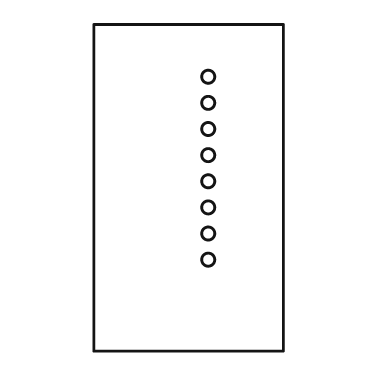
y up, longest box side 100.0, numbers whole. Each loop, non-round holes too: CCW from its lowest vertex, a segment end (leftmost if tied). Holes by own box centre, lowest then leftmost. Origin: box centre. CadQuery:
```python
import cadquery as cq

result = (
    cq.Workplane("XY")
    .moveTo(-29.0, -50.0)
    .lineTo(29.0, -50.0)
    .lineTo(29.0, 50.0)
    .lineTo(-29.0, 50.0)
    .close()
    .moveTo(6.0, -22.0)
    .circle(2.0)
    .moveTo(6.0, -14.0)
    .circle(2.0)
    .moveTo(6.0, -6.0)
    .circle(2.0)
    .moveTo(6.0, 2.0)
    .circle(2.0)
    .moveTo(6.0, 10.0)
    .circle(2.0)
    .moveTo(6.0, 18.0)
    .circle(2.0)
    .moveTo(6.0, 26.0)
    .circle(2.0)
    .moveTo(6.0, 34.0)
    .circle(2.0)
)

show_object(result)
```